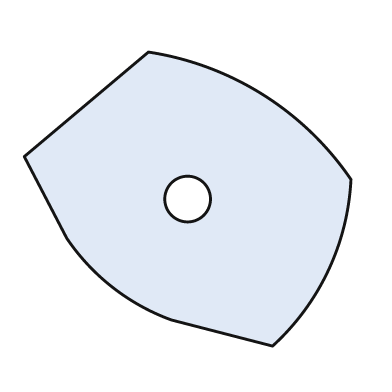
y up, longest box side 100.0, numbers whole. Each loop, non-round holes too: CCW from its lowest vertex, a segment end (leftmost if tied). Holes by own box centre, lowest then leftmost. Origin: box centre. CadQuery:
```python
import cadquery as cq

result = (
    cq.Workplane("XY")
    .moveTo(26.0, -45.0)
    .threePointArc((43.0, -22.0), (50.0, 6.0))
    .threePointArc((23.0, 32.0), (-12.0, 45.0))
    .lineTo(-50.0, 13.0)
    .lineTo(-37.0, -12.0)
    .threePointArc((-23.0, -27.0), (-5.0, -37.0))
    .close()
    .moveTo(0.0, 0.0)
    .circle(7.0)
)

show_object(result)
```